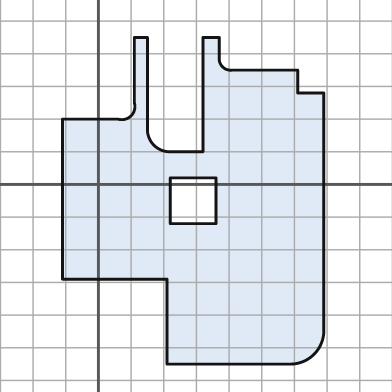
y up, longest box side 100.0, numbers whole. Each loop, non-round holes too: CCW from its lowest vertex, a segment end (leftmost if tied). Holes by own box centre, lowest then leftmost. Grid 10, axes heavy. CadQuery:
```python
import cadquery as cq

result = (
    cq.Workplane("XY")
    .moveTo(21.0, -55.0)
    .lineTo(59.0, -55.0)
    .threePointArc((66.0, -52.0), (69.0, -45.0))
    .lineTo(69.0, 28.0)
    .lineTo(61.0, 28.0)
    .lineTo(61.0, 35.0)
    .lineTo(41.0, 35.0)
    .threePointArc((38.0, 36.0), (37.0, 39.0))
    .lineTo(37.0, 45.0)
    .lineTo(32.0, 45.0)
    .lineTo(32.0, 10.0)
    .lineTo(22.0, 10.0)
    .threePointArc((17.0, 12.0), (15.0, 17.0))
    .lineTo(15.0, 45.0)
    .lineTo(11.0, 45.0)
    .lineTo(11.0, 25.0)
    .threePointArc((10.0, 21.0), (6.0, 20.0))
    .lineTo(-11.0, 20.0)
    .lineTo(-11.0, -29.0)
    .lineTo(21.0, -29.0)
    .close()
    .moveTo(22.0, -12.0)
    .lineTo(36.0, -12.0)
    .lineTo(36.0, 2.0)
    .lineTo(22.0, 2.0)
    .close()
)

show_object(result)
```